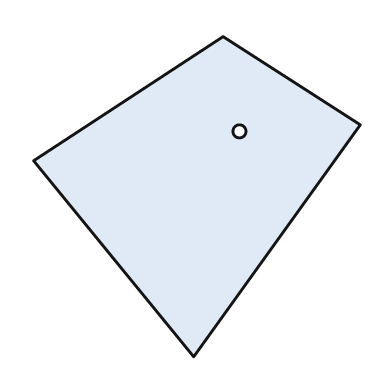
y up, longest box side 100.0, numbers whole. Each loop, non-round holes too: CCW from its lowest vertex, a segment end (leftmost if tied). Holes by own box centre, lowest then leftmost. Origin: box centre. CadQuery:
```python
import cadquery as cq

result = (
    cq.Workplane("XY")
    .moveTo(-1.0, -49.0)
    .lineTo(50.0, 22.0)
    .lineTo(8.0, 49.0)
    .lineTo(-50.0, 11.0)
    .close()
    .moveTo(13.0, 20.0)
    .circle(2.0)
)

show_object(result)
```